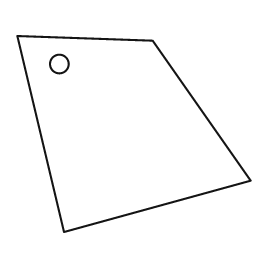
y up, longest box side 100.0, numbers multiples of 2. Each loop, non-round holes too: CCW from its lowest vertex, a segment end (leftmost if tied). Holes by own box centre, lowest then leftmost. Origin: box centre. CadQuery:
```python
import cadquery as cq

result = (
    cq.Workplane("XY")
    .moveTo(-30.0, -42.0)
    .lineTo(50.0, -20.0)
    .lineTo(8.0, 40.0)
    .lineTo(-50.0, 42.0)
    .close()
    .moveTo(-32.0, 30.0)
    .circle(4.0)
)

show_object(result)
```